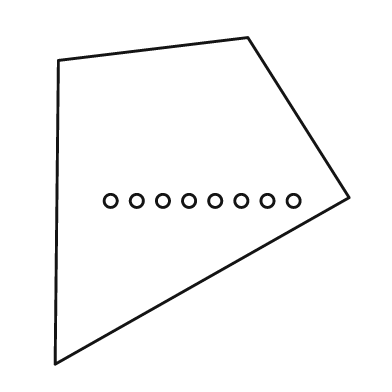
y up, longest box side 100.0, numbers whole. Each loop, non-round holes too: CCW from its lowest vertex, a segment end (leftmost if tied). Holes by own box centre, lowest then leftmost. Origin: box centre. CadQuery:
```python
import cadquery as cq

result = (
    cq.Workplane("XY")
    .moveTo(-45.0, -50.0)
    .lineTo(45.0, 1.0)
    .lineTo(14.0, 50.0)
    .lineTo(-44.0, 43.0)
    .close()
    .moveTo(-28.0, 0.0)
    .circle(2.0)
    .moveTo(-20.0, 0.0)
    .circle(2.0)
    .moveTo(-12.0, 0.0)
    .circle(2.0)
    .moveTo(-4.0, 0.0)
    .circle(2.0)
    .moveTo(4.0, 0.0)
    .circle(2.0)
    .moveTo(12.0, 0.0)
    .circle(2.0)
    .moveTo(20.0, 0.0)
    .circle(2.0)
    .moveTo(28.0, 0.0)
    .circle(2.0)
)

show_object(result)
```